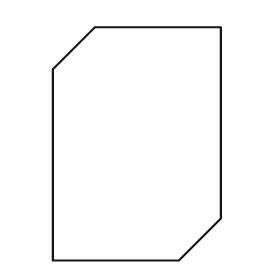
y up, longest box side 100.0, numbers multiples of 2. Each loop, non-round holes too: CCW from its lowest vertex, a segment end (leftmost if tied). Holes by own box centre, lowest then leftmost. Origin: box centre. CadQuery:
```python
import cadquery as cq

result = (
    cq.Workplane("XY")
    .moveTo(-36.0, -50.0)
    .lineTo(18.0, -50.0)
    .lineTo(36.0, -32.0)
    .lineTo(36.0, 50.0)
    .lineTo(-18.0, 50.0)
    .lineTo(-36.0, 32.0)
    .close()
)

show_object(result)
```